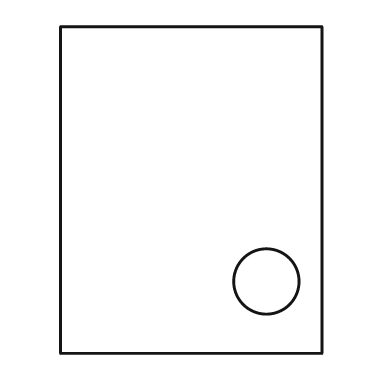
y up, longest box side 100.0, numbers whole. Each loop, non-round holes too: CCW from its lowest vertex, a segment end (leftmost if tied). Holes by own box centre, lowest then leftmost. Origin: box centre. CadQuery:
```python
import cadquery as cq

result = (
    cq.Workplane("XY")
    .moveTo(-40.0, -50.0)
    .lineTo(40.0, -50.0)
    .lineTo(40.0, 50.0)
    .lineTo(-40.0, 50.0)
    .close()
    .moveTo(23.0, -28.0)
    .circle(10.0)
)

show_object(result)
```